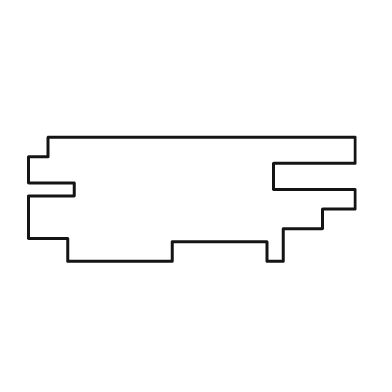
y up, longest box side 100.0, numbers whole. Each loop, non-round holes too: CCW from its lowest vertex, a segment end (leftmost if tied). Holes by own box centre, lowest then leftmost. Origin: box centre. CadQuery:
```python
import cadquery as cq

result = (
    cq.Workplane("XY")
    .moveTo(-38.0, -19.0)
    .lineTo(-6.0, -19.0)
    .lineTo(-6.0, -13.0)
    .lineTo(23.0, -13.0)
    .lineTo(23.0, -19.0)
    .lineTo(28.0, -19.0)
    .lineTo(28.0, -9.0)
    .lineTo(40.0, -9.0)
    .lineTo(40.0, -3.0)
    .lineTo(50.0, -3.0)
    .lineTo(50.0, 3.0)
    .lineTo(25.0, 3.0)
    .lineTo(25.0, 11.0)
    .lineTo(50.0, 11.0)
    .lineTo(50.0, 19.0)
    .lineTo(-44.0, 19.0)
    .lineTo(-44.0, 13.0)
    .lineTo(-50.0, 13.0)
    .lineTo(-50.0, 5.0)
    .lineTo(-36.0, 5.0)
    .lineTo(-36.0, 1.0)
    .lineTo(-50.0, 1.0)
    .lineTo(-50.0, -12.0)
    .lineTo(-38.0, -12.0)
    .close()
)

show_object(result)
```